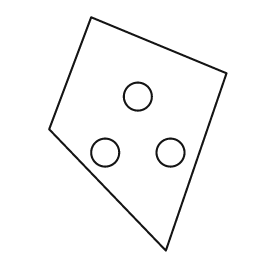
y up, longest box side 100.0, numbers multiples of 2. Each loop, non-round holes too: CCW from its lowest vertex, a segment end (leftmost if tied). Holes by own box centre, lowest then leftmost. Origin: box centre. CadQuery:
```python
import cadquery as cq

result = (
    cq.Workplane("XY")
    .moveTo(12.0, -50.0)
    .lineTo(38.0, 26.0)
    .lineTo(-20.0, 50.0)
    .lineTo(-38.0, 2.0)
    .close()
    .moveTo(-14.0, -8.0)
    .circle(6.0)
    .moveTo(14.0, -8.0)
    .circle(6.0)
    .moveTo(0.0, 16.0)
    .circle(6.0)
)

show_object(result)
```